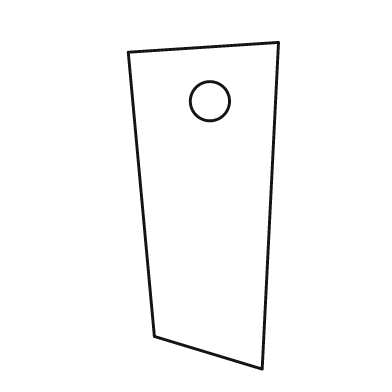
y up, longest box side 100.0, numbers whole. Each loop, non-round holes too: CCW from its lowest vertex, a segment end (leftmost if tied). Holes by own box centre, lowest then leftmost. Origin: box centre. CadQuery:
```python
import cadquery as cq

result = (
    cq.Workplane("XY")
    .moveTo(18.0, -50.0)
    .lineTo(23.0, 50.0)
    .lineTo(-23.0, 47.0)
    .lineTo(-15.0, -40.0)
    .close()
    .moveTo(2.0, 32.0)
    .circle(6.0)
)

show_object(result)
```